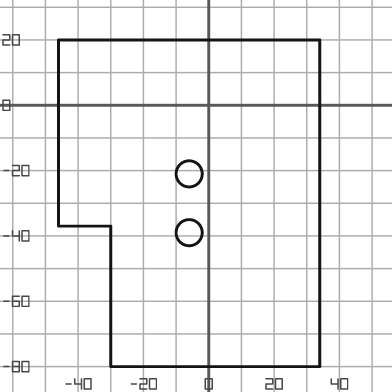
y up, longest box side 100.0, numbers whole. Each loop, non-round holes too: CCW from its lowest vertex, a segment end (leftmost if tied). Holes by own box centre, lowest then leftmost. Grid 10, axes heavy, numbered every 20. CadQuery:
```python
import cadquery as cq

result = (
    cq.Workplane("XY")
    .moveTo(-30.0, -80.0)
    .lineTo(34.0, -80.0)
    .lineTo(34.0, 20.0)
    .lineTo(-46.0, 20.0)
    .lineTo(-46.0, -37.0)
    .lineTo(-30.0, -37.0)
    .close()
    .moveTo(-6.0, -39.0)
    .circle(4.0)
    .moveTo(-6.0, -21.0)
    .circle(4.0)
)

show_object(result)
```